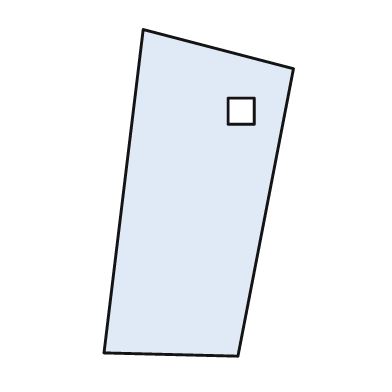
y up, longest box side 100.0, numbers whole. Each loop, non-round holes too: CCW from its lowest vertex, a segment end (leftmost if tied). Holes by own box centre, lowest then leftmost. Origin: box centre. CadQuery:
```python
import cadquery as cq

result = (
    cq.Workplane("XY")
    .moveTo(12.0, -50.0)
    .lineTo(29.0, 38.0)
    .lineTo(-17.0, 50.0)
    .lineTo(-29.0, -49.0)
    .close()
    .moveTo(9.0, 21.0)
    .lineTo(17.0, 21.0)
    .lineTo(17.0, 29.0)
    .lineTo(9.0, 29.0)
    .close()
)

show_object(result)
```